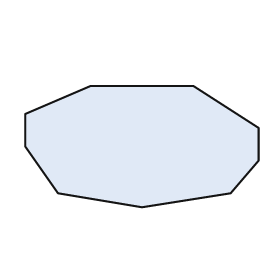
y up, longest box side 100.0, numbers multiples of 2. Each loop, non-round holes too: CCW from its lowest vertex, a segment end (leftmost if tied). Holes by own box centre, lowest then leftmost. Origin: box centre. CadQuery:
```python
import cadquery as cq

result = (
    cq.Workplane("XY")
    .moveTo(0.0, -26.0)
    .lineTo(38.0, -20.0)
    .lineTo(50.0, -6.0)
    .lineTo(50.0, 8.0)
    .lineTo(22.0, 26.0)
    .lineTo(-22.0, 26.0)
    .lineTo(-50.0, 14.0)
    .lineTo(-50.0, 0.0)
    .lineTo(-36.0, -20.0)
    .close()
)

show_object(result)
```